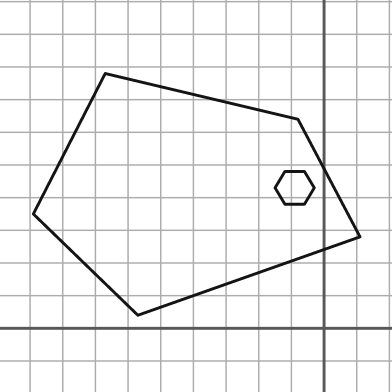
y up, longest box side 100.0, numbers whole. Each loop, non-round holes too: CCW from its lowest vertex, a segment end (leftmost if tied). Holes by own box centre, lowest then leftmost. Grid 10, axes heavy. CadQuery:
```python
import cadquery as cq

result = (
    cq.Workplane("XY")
    .moveTo(-57.0, 4.0)
    .lineTo(11.0, 28.0)
    .lineTo(-8.0, 64.0)
    .lineTo(-67.0, 78.0)
    .lineTo(-89.0, 35.0)
    .close()
    .moveTo(-12.0, 38.0)
    .lineTo(-6.0, 38.0)
    .lineTo(-3.0, 43.0)
    .lineTo(-6.0, 48.0)
    .lineTo(-12.0, 48.0)
    .lineTo(-15.0, 43.0)
    .close()
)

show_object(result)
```